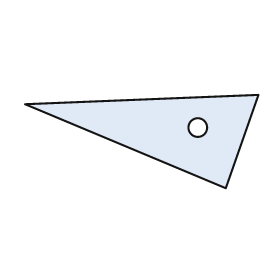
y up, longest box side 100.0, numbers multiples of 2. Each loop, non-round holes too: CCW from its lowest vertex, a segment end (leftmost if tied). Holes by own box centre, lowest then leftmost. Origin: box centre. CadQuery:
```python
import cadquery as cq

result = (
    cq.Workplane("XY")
    .moveTo(36.0, -20.0)
    .lineTo(50.0, 20.0)
    .lineTo(-50.0, 16.0)
    .close()
    .moveTo(24.0, 6.0)
    .circle(4.0)
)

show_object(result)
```